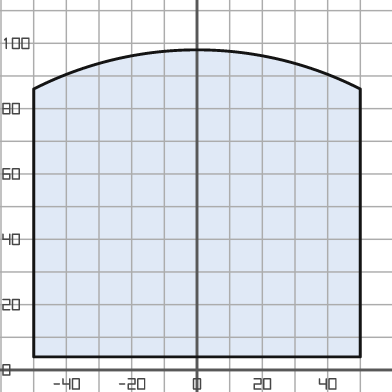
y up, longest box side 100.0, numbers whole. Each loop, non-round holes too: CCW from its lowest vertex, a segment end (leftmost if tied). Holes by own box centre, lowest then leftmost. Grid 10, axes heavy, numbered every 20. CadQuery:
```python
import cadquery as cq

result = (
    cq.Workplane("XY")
    .moveTo(-50.0, 4.0)
    .lineTo(50.0, 4.0)
    .lineTo(50.0, 86.0)
    .threePointArc((0.0, 98.0), (-50.0, 86.0))
    .close()
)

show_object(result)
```